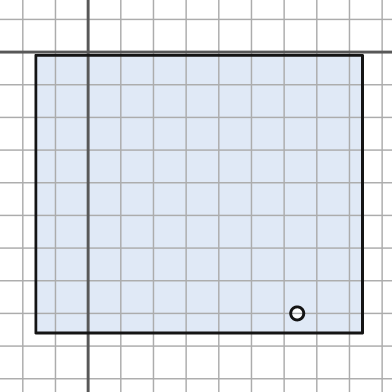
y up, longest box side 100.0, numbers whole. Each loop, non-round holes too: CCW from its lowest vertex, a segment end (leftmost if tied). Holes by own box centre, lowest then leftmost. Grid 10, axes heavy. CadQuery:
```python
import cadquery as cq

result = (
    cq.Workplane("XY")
    .moveTo(-16.0, -86.0)
    .lineTo(84.0, -86.0)
    .lineTo(84.0, -1.0)
    .lineTo(-16.0, -1.0)
    .close()
    .moveTo(64.0, -80.0)
    .circle(2.0)
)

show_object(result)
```